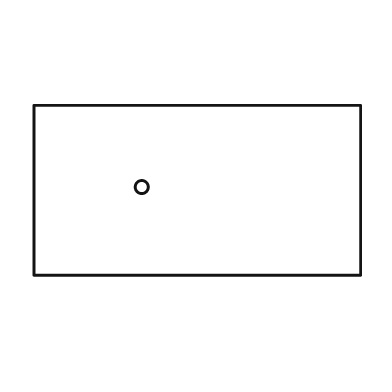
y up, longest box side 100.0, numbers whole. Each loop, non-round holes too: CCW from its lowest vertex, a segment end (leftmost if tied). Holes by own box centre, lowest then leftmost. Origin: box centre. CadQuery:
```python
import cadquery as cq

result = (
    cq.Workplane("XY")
    .moveTo(-50.0, -26.0)
    .lineTo(50.0, -26.0)
    .lineTo(50.0, 26.0)
    .lineTo(-50.0, 26.0)
    .close()
    .moveTo(-17.0, 1.0)
    .circle(2.0)
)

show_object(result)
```